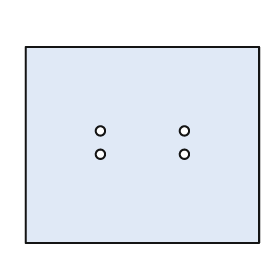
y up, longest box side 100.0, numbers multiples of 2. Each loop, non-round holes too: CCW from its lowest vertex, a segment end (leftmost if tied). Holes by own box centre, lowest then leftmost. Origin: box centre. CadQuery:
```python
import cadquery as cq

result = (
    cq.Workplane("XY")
    .moveTo(-50.0, -42.0)
    .lineTo(50.0, -42.0)
    .lineTo(50.0, 42.0)
    .lineTo(-50.0, 42.0)
    .close()
    .moveTo(-18.0, -4.0)
    .circle(2.0)
    .moveTo(18.0, -4.0)
    .circle(2.0)
    .moveTo(-18.0, 6.0)
    .circle(2.0)
    .moveTo(18.0, 6.0)
    .circle(2.0)
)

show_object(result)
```